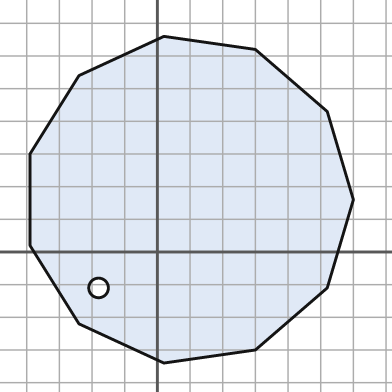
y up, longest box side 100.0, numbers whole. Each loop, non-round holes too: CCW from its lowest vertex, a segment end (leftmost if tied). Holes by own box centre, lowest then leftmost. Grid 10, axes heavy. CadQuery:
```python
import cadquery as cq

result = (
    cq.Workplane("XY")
    .moveTo(2.0, -34.0)
    .lineTo(30.0, -30.0)
    .lineTo(52.0, -11.0)
    .lineTo(60.0, 16.0)
    .lineTo(52.0, 43.0)
    .lineTo(30.0, 62.0)
    .lineTo(2.0, 66.0)
    .lineTo(-24.0, 54.0)
    .lineTo(-39.0, 30.0)
    .lineTo(-39.0, 2.0)
    .lineTo(-24.0, -22.0)
    .close()
    .moveTo(-18.0, -11.0)
    .circle(3.0)
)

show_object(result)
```